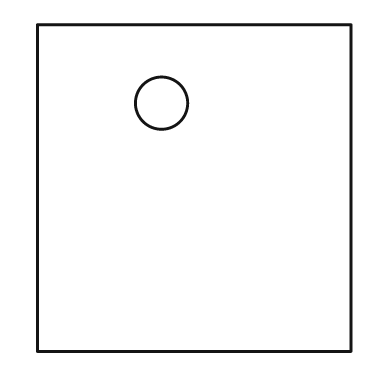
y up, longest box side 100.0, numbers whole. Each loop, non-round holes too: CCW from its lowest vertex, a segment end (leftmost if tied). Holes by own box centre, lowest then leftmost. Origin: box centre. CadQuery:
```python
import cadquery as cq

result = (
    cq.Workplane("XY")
    .moveTo(-48.0, -50.0)
    .lineTo(48.0, -50.0)
    .lineTo(48.0, 50.0)
    .lineTo(-48.0, 50.0)
    .close()
    .moveTo(-10.0, 26.0)
    .circle(8.0)
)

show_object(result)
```